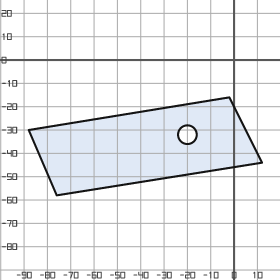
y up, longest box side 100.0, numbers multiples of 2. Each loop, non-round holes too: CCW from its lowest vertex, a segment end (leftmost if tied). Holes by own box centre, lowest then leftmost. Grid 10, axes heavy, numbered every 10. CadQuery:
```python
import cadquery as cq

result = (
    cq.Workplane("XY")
    .moveTo(-76.0, -58.0)
    .lineTo(12.0, -44.0)
    .lineTo(-2.0, -16.0)
    .lineTo(-88.0, -30.0)
    .close()
    .moveTo(-20.0, -32.0)
    .circle(4.0)
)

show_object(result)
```